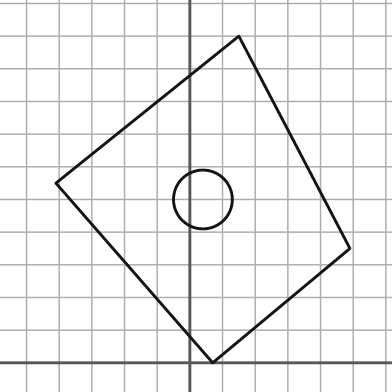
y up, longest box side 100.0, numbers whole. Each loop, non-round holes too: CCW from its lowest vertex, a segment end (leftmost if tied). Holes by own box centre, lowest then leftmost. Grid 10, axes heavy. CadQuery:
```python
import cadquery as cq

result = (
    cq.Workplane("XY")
    .moveTo(7.0, 0.0)
    .lineTo(49.0, 35.0)
    .lineTo(15.0, 100.0)
    .lineTo(-41.0, 55.0)
    .close()
    .moveTo(4.0, 50.0)
    .circle(9.0)
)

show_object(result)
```